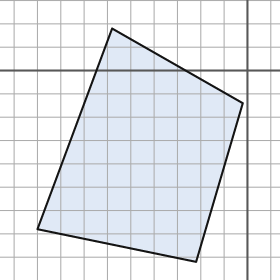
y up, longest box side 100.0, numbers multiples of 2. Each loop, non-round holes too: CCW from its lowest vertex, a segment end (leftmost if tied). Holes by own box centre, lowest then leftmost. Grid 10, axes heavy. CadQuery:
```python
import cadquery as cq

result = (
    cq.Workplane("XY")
    .moveTo(-22.0, -82.0)
    .lineTo(-2.0, -14.0)
    .lineTo(-58.0, 18.0)
    .lineTo(-90.0, -68.0)
    .close()
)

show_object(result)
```